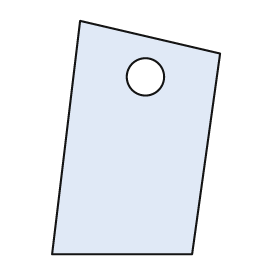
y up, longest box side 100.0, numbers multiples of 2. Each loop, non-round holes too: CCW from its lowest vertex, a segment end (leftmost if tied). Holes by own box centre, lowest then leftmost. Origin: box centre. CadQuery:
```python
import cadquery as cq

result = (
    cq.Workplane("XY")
    .moveTo(-36.0, -50.0)
    .lineTo(24.0, -50.0)
    .lineTo(36.0, 36.0)
    .lineTo(-24.0, 50.0)
    .close()
    .moveTo(4.0, 26.0)
    .circle(8.0)
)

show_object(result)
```